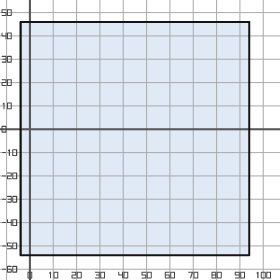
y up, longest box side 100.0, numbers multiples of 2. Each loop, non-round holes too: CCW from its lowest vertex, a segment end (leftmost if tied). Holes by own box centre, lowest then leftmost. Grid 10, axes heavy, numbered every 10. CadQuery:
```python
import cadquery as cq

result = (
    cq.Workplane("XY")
    .moveTo(-4.0, -54.0)
    .lineTo(94.0, -54.0)
    .lineTo(94.0, 46.0)
    .lineTo(-4.0, 46.0)
    .close()
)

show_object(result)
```